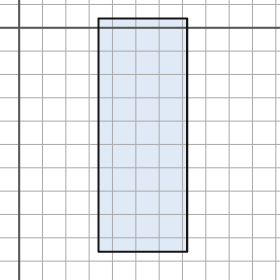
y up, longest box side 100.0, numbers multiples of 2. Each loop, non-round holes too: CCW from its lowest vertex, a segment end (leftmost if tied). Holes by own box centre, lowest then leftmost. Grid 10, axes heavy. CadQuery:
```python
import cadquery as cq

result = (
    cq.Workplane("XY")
    .moveTo(34.0, -96.0)
    .lineTo(72.0, -96.0)
    .lineTo(72.0, 4.0)
    .lineTo(34.0, 4.0)
    .close()
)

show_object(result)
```